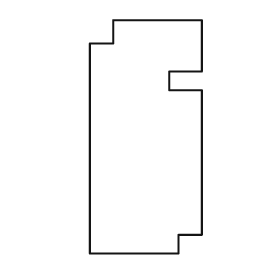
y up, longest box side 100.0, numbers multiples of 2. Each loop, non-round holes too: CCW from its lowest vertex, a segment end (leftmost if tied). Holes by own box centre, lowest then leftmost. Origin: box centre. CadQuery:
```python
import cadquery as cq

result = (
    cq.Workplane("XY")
    .moveTo(-24.0, -50.0)
    .lineTo(14.0, -50.0)
    .lineTo(14.0, -42.0)
    .lineTo(24.0, -42.0)
    .lineTo(24.0, 20.0)
    .lineTo(10.0, 20.0)
    .lineTo(10.0, 28.0)
    .lineTo(24.0, 28.0)
    .lineTo(24.0, 50.0)
    .lineTo(-14.0, 50.0)
    .lineTo(-14.0, 40.0)
    .lineTo(-24.0, 40.0)
    .close()
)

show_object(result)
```